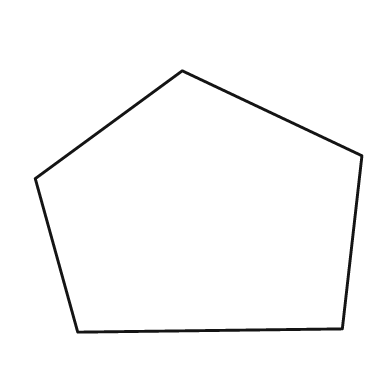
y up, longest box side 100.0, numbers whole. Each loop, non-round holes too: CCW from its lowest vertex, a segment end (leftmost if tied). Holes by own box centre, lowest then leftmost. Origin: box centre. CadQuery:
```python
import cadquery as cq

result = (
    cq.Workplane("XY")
    .moveTo(-37.0, -40.0)
    .lineTo(44.0, -39.0)
    .lineTo(50.0, 14.0)
    .lineTo(-5.0, 40.0)
    .lineTo(-50.0, 7.0)
    .close()
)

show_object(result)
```